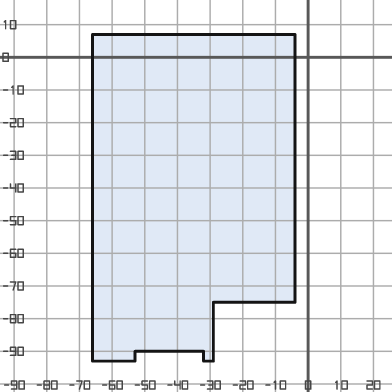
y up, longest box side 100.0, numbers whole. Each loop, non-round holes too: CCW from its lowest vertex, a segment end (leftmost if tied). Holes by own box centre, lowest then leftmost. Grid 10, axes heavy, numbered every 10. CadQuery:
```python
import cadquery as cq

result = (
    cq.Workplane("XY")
    .moveTo(-66.0, -93.0)
    .lineTo(-53.0, -93.0)
    .lineTo(-53.0, -90.0)
    .lineTo(-32.0, -90.0)
    .lineTo(-32.0, -93.0)
    .lineTo(-29.0, -93.0)
    .lineTo(-29.0, -75.0)
    .lineTo(-4.0, -75.0)
    .lineTo(-4.0, 7.0)
    .lineTo(-66.0, 7.0)
    .close()
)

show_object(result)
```